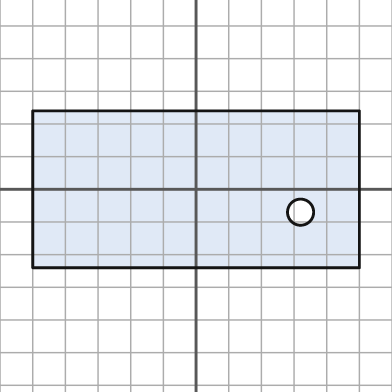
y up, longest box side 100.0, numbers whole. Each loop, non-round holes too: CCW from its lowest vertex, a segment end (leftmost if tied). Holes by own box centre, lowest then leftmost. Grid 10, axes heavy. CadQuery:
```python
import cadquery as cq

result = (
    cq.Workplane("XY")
    .moveTo(-50.0, -24.0)
    .lineTo(50.0, -24.0)
    .lineTo(50.0, 24.0)
    .lineTo(-50.0, 24.0)
    .close()
    .moveTo(32.0, -7.0)
    .circle(4.0)
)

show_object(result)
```